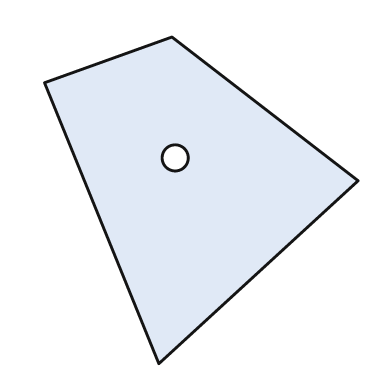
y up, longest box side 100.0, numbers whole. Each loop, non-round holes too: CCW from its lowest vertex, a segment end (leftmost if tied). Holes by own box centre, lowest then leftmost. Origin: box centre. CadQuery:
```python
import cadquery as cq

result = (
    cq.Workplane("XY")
    .moveTo(-13.0, -50.0)
    .lineTo(48.0, 6.0)
    .lineTo(-9.0, 50.0)
    .lineTo(-48.0, 36.0)
    .close()
    .moveTo(-8.0, 13.0)
    .circle(4.0)
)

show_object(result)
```